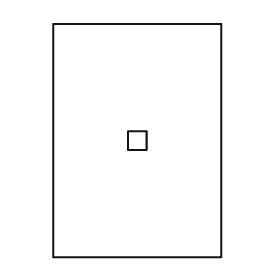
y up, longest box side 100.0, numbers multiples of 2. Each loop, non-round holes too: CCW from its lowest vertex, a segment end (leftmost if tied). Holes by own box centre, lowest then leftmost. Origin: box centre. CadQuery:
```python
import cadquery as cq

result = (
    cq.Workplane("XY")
    .moveTo(-36.0, -50.0)
    .lineTo(36.0, -50.0)
    .lineTo(36.0, 50.0)
    .lineTo(-36.0, 50.0)
    .close()
    .moveTo(-4.0, -4.0)
    .lineTo(4.0, -4.0)
    .lineTo(4.0, 4.0)
    .lineTo(-4.0, 4.0)
    .close()
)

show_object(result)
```